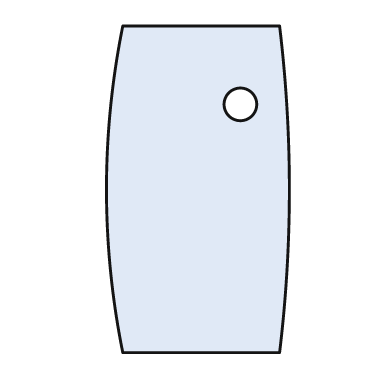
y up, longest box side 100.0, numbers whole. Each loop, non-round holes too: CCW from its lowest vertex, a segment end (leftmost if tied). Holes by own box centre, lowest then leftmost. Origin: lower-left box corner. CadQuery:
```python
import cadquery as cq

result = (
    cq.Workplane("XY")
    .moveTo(5.0, 0.0)
    .lineTo(53.0, 0.0)
    .threePointArc((56.0, 50.0), (53.0, 100.0))
    .lineTo(5.0, 100.0)
    .threePointArc((0.0, 50.0), (5.0, 0.0))
    .close()
    .moveTo(41.0, 76.0)
    .circle(5.0)
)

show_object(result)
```